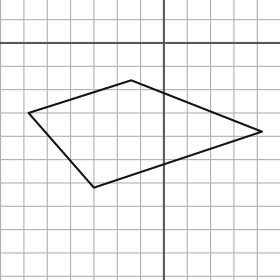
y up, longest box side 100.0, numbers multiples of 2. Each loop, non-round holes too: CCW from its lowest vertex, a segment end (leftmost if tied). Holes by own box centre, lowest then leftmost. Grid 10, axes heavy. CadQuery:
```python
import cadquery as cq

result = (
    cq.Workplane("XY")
    .moveTo(-30.0, -62.0)
    .lineTo(42.0, -38.0)
    .lineTo(-14.0, -16.0)
    .lineTo(-58.0, -30.0)
    .close()
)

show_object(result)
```